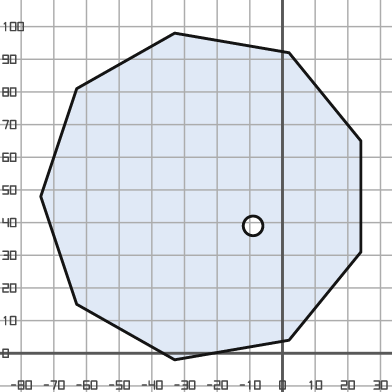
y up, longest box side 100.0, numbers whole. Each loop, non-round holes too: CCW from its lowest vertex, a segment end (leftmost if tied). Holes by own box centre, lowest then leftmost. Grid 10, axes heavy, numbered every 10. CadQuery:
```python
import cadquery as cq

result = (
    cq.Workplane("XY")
    .moveTo(-33.0, -2.0)
    .lineTo(2.0, 4.0)
    .lineTo(24.0, 31.0)
    .lineTo(24.0, 65.0)
    .lineTo(2.0, 92.0)
    .lineTo(-33.0, 98.0)
    .lineTo(-63.0, 81.0)
    .lineTo(-74.0, 48.0)
    .lineTo(-63.0, 15.0)
    .close()
    .moveTo(-9.0, 39.0)
    .circle(3.0)
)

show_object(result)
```